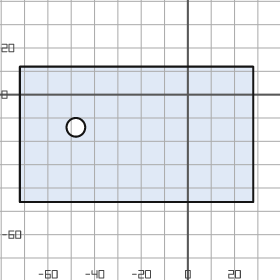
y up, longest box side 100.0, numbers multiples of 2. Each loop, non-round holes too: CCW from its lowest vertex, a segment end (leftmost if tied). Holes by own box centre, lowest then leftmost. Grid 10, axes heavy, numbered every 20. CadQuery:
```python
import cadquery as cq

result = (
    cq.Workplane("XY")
    .moveTo(-72.0, -46.0)
    .lineTo(28.0, -46.0)
    .lineTo(28.0, 12.0)
    .lineTo(-72.0, 12.0)
    .close()
    .moveTo(-48.0, -14.0)
    .circle(4.0)
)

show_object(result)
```